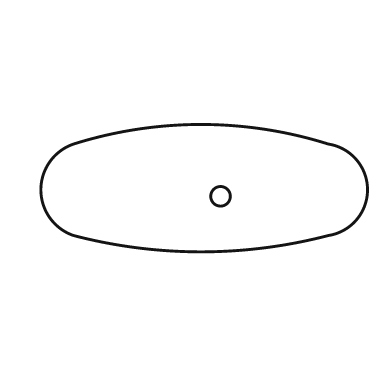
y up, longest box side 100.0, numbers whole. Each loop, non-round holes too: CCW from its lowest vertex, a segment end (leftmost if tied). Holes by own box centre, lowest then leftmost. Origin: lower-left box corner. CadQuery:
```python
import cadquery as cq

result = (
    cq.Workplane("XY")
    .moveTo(10.0, 5.0)
    .threePointArc((49.0, 0.0), (88.0, 5.0))
    .threePointArc((100.0, 19.0), (88.0, 33.0))
    .threePointArc((49.0, 39.0), (10.0, 33.0))
    .threePointArc((0.0, 19.0), (10.0, 5.0))
    .close()
    .moveTo(55.0, 17.0)
    .circle(3.0)
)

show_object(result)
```